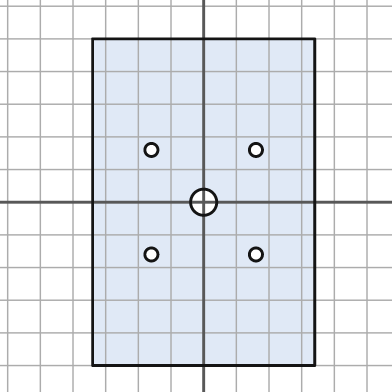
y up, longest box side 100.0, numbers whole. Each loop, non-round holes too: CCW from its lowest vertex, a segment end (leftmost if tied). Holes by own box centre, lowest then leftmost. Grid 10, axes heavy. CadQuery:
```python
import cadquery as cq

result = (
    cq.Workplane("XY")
    .moveTo(-34.0, -50.0)
    .lineTo(34.0, -50.0)
    .lineTo(34.0, 50.0)
    .lineTo(-34.0, 50.0)
    .close()
    .moveTo(-16.0, -16.0)
    .circle(2.0)
    .moveTo(16.0, -16.0)
    .circle(2.0)
    .moveTo(0.0, 0.0)
    .circle(4.0)
    .moveTo(-16.0, 16.0)
    .circle(2.0)
    .moveTo(16.0, 16.0)
    .circle(2.0)
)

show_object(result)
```